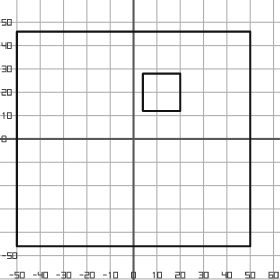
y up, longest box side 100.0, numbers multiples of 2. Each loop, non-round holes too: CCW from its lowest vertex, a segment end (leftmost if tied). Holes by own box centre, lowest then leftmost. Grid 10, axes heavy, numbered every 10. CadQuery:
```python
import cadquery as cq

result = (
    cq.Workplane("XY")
    .moveTo(-50.0, -46.0)
    .lineTo(50.0, -46.0)
    .lineTo(50.0, 46.0)
    .lineTo(-50.0, 46.0)
    .close()
    .moveTo(4.0, 12.0)
    .lineTo(20.0, 12.0)
    .lineTo(20.0, 28.0)
    .lineTo(4.0, 28.0)
    .close()
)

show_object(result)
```